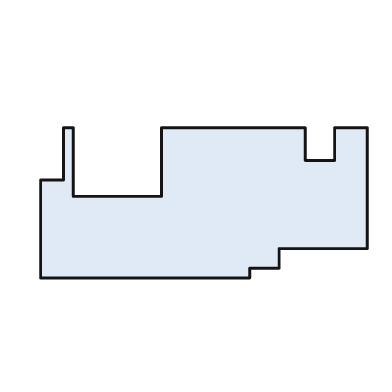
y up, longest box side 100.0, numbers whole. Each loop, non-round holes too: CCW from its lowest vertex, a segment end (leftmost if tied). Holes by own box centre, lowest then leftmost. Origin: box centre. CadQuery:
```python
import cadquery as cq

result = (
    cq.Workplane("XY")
    .moveTo(-50.0, -23.0)
    .lineTo(14.0, -23.0)
    .lineTo(14.0, -20.0)
    .lineTo(23.0, -20.0)
    .lineTo(23.0, -14.0)
    .lineTo(50.0, -14.0)
    .lineTo(50.0, 23.0)
    .lineTo(40.0, 23.0)
    .lineTo(40.0, 13.0)
    .lineTo(31.0, 13.0)
    .lineTo(31.0, 23.0)
    .lineTo(-13.0, 23.0)
    .lineTo(-13.0, 2.0)
    .lineTo(-40.0, 2.0)
    .lineTo(-40.0, 23.0)
    .lineTo(-43.0, 23.0)
    .lineTo(-43.0, 7.0)
    .lineTo(-50.0, 7.0)
    .close()
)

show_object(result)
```